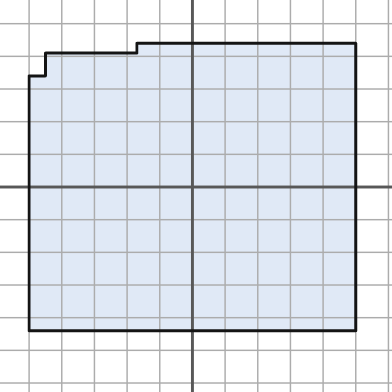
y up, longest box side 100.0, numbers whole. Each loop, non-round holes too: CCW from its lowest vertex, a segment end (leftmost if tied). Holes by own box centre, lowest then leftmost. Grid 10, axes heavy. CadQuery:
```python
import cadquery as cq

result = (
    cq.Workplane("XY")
    .moveTo(-50.0, -44.0)
    .lineTo(50.0, -44.0)
    .lineTo(50.0, 44.0)
    .lineTo(-17.0, 44.0)
    .lineTo(-17.0, 41.0)
    .lineTo(-45.0, 41.0)
    .lineTo(-45.0, 34.0)
    .lineTo(-50.0, 34.0)
    .close()
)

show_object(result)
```